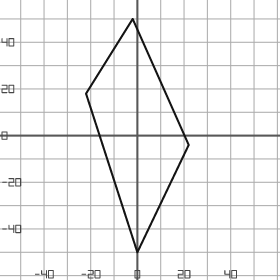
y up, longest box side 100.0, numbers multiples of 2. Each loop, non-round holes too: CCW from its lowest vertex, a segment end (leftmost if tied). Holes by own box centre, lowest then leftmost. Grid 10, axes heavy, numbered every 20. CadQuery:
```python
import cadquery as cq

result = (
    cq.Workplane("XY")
    .moveTo(0.0, -50.0)
    .lineTo(22.0, -4.0)
    .lineTo(-2.0, 50.0)
    .lineTo(-22.0, 18.0)
    .close()
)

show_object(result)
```